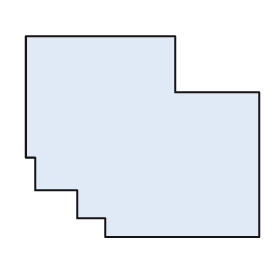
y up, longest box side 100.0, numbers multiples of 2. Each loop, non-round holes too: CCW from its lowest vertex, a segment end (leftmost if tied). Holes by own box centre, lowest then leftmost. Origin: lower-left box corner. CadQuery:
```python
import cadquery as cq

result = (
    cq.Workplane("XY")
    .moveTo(34.0, 0.0)
    .lineTo(100.0, 0.0)
    .lineTo(100.0, 62.0)
    .lineTo(64.0, 62.0)
    .lineTo(64.0, 86.0)
    .lineTo(0.0, 86.0)
    .lineTo(0.0, 34.0)
    .lineTo(4.0, 34.0)
    .lineTo(4.0, 20.0)
    .lineTo(22.0, 20.0)
    .lineTo(22.0, 8.0)
    .lineTo(34.0, 8.0)
    .close()
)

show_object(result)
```